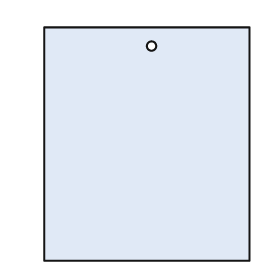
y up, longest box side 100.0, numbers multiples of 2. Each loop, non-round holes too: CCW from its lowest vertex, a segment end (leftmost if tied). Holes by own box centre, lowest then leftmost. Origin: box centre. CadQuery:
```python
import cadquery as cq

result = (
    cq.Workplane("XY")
    .moveTo(-44.0, -50.0)
    .lineTo(44.0, -50.0)
    .lineTo(44.0, 50.0)
    .lineTo(-44.0, 50.0)
    .close()
    .moveTo(2.0, 42.0)
    .circle(2.0)
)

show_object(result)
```